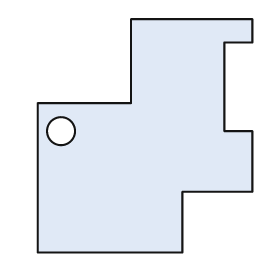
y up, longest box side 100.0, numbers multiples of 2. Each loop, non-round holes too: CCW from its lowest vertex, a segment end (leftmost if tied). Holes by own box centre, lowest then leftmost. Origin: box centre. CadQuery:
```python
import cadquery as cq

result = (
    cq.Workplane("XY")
    .moveTo(-46.0, -50.0)
    .lineTo(16.0, -50.0)
    .lineTo(16.0, -24.0)
    .lineTo(46.0, -24.0)
    .lineTo(46.0, 2.0)
    .lineTo(34.0, 2.0)
    .lineTo(34.0, 40.0)
    .lineTo(46.0, 40.0)
    .lineTo(46.0, 50.0)
    .lineTo(-6.0, 50.0)
    .lineTo(-6.0, 14.0)
    .lineTo(-46.0, 14.0)
    .close()
    .moveTo(-36.0, 2.0)
    .circle(6.0)
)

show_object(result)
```